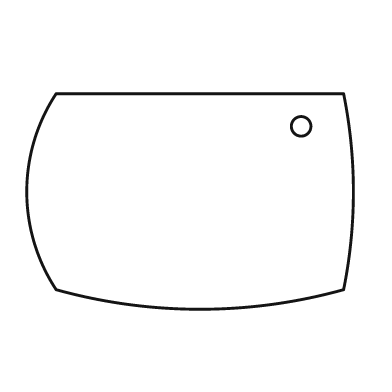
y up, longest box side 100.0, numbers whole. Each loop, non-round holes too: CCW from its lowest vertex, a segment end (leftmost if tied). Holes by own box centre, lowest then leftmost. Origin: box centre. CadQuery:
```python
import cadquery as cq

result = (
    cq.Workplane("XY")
    .moveTo(-41.0, -27.0)
    .threePointArc((3.0, -33.0), (47.0, -27.0))
    .threePointArc((50.0, 3.0), (47.0, 33.0))
    .lineTo(-41.0, 33.0)
    .threePointArc((-50.0, 3.0), (-41.0, -27.0))
    .close()
    .moveTo(34.0, 23.0)
    .circle(3.0)
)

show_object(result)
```